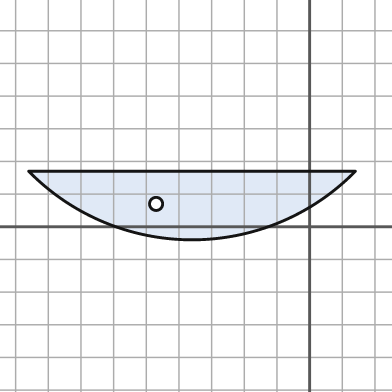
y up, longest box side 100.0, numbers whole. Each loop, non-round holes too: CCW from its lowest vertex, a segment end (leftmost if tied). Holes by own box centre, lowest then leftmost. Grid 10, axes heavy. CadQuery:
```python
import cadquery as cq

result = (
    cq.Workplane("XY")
    .moveTo(-86.0, 17.0)
    .threePointArc((-36.0, -4.0), (14.0, 17.0))
    .close()
    .moveTo(-47.0, 7.0)
    .circle(2.0)
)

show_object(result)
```